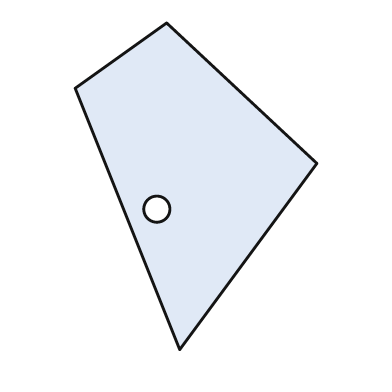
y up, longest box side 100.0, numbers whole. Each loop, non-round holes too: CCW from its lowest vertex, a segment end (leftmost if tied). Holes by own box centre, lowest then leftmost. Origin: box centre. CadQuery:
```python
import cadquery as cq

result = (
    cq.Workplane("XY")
    .moveTo(-5.0, -50.0)
    .lineTo(37.0, 7.0)
    .lineTo(-9.0, 50.0)
    .lineTo(-37.0, 30.0)
    .close()
    .moveTo(-12.0, -7.0)
    .circle(4.0)
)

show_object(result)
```